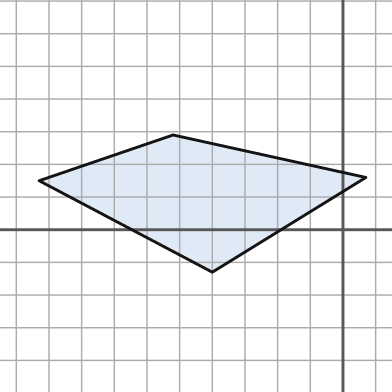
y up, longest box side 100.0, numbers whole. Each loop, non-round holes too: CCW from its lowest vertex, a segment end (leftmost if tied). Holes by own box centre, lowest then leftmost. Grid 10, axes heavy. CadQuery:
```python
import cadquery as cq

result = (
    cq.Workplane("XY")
    .moveTo(-40.0, -13.0)
    .lineTo(7.0, 16.0)
    .lineTo(-52.0, 29.0)
    .lineTo(-93.0, 15.0)
    .close()
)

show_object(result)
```